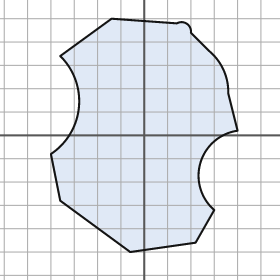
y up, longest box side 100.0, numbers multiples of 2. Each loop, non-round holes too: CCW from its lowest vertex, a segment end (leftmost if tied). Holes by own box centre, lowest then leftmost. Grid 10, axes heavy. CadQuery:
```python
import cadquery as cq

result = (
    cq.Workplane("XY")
    .moveTo(-6.0, -50.0)
    .lineTo(22.0, -46.0)
    .lineTo(30.0, -32.0)
    .threePointArc((24.0, -12.0), (40.0, 2.0))
    .lineTo(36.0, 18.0)
    .threePointArc((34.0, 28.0), (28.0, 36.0))
    .lineTo(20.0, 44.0)
    .threePointArc((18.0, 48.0), (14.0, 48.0))
    .lineTo(-14.0, 50.0)
    .lineTo(-36.0, 34.0)
    .threePointArc((-28.0, 12.0), (-40.0, -8.0))
    .lineTo(-36.0, -28.0)
    .close()
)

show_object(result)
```